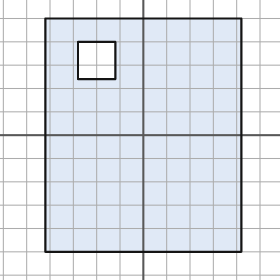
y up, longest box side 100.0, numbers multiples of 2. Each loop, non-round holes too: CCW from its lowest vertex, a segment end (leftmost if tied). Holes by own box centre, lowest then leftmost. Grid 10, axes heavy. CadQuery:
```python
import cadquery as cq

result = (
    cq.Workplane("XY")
    .moveTo(-42.0, -50.0)
    .lineTo(42.0, -50.0)
    .lineTo(42.0, 50.0)
    .lineTo(-42.0, 50.0)
    .close()
    .moveTo(-28.0, 24.0)
    .lineTo(-12.0, 24.0)
    .lineTo(-12.0, 40.0)
    .lineTo(-28.0, 40.0)
    .close()
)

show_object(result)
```